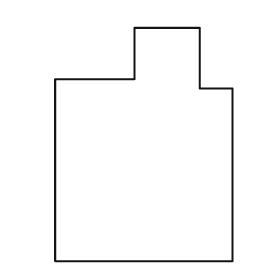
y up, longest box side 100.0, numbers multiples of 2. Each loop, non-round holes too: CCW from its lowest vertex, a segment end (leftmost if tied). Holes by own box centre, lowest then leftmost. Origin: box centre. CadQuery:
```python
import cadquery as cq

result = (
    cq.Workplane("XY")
    .moveTo(-38.0, -50.0)
    .lineTo(38.0, -50.0)
    .lineTo(38.0, 24.0)
    .lineTo(24.0, 24.0)
    .lineTo(24.0, 50.0)
    .lineTo(-4.0, 50.0)
    .lineTo(-4.0, 28.0)
    .lineTo(-38.0, 28.0)
    .close()
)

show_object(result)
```